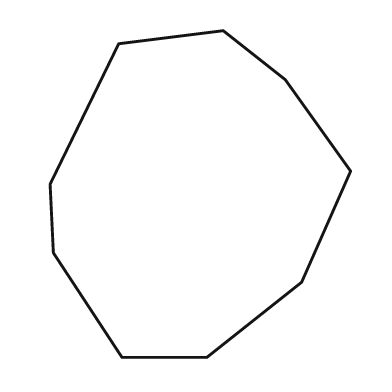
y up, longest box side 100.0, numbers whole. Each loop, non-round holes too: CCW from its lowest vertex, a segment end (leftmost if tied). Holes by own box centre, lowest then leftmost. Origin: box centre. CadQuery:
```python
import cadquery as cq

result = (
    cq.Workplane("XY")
    .moveTo(-24.0, -50.0)
    .lineTo(2.0, -50.0)
    .lineTo(31.0, -27.0)
    .lineTo(46.0, 7.0)
    .lineTo(26.0, 35.0)
    .lineTo(7.0, 50.0)
    .lineTo(-25.0, 46.0)
    .lineTo(-46.0, 3.0)
    .lineTo(-45.0, -18.0)
    .close()
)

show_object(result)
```